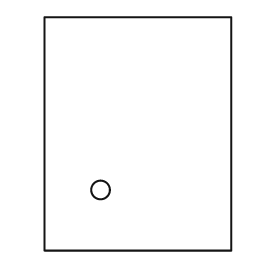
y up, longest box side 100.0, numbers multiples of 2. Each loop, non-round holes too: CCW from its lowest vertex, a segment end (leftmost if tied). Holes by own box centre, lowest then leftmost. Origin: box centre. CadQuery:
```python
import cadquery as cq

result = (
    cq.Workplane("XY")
    .moveTo(-40.0, -50.0)
    .lineTo(40.0, -50.0)
    .lineTo(40.0, 50.0)
    .lineTo(-40.0, 50.0)
    .close()
    .moveTo(-16.0, -24.0)
    .circle(4.0)
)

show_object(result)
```